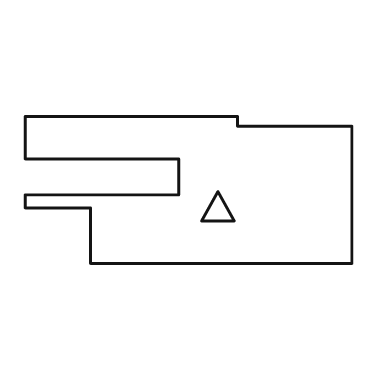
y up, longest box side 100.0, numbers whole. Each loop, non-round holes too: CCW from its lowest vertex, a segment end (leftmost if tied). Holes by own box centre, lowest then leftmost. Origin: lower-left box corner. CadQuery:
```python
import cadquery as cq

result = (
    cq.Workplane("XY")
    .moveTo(20.0, 0.0)
    .lineTo(100.0, 0.0)
    .lineTo(100.0, 42.0)
    .lineTo(65.0, 42.0)
    .lineTo(65.0, 45.0)
    .lineTo(0.0, 45.0)
    .lineTo(0.0, 32.0)
    .lineTo(47.0, 32.0)
    .lineTo(47.0, 21.0)
    .lineTo(0.0, 21.0)
    .lineTo(0.0, 17.0)
    .lineTo(20.0, 17.0)
    .close()
    .moveTo(54.0, 13.0)
    .lineTo(64.0, 13.0)
    .lineTo(59.0, 22.0)
    .close()
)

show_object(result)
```